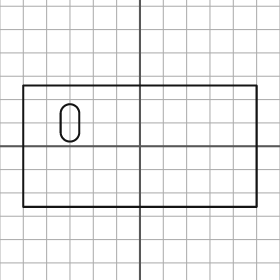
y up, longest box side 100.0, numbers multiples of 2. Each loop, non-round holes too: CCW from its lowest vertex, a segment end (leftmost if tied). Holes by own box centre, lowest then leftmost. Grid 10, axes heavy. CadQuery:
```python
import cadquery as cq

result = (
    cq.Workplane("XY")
    .moveTo(-50.0, -26.0)
    .lineTo(50.0, -26.0)
    .lineTo(50.0, 26.0)
    .lineTo(-50.0, 26.0)
    .close()
    .moveTo(-34.0, 6.0)
    .threePointArc((-30.0, 2.0), (-26.0, 6.0))
    .lineTo(-26.0, 14.0)
    .threePointArc((-30.0, 18.0), (-34.0, 14.0))
    .close()
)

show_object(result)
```